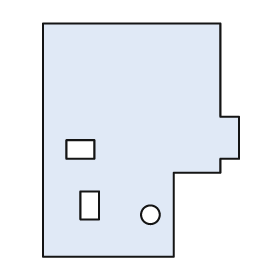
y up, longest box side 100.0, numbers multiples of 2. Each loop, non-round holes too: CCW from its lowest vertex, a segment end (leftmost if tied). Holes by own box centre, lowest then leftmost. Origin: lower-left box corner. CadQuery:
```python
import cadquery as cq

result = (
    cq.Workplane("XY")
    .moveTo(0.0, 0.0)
    .lineTo(56.0, 0.0)
    .lineTo(56.0, 36.0)
    .lineTo(76.0, 36.0)
    .lineTo(76.0, 42.0)
    .lineTo(84.0, 42.0)
    .lineTo(84.0, 60.0)
    .lineTo(76.0, 60.0)
    .lineTo(76.0, 100.0)
    .lineTo(0.0, 100.0)
    .close()
    .moveTo(46.0, 18.0)
    .circle(4.0)
    .moveTo(16.0, 16.0)
    .lineTo(24.0, 16.0)
    .lineTo(24.0, 28.0)
    .lineTo(16.0, 28.0)
    .close()
    .moveTo(10.0, 42.0)
    .lineTo(22.0, 42.0)
    .lineTo(22.0, 50.0)
    .lineTo(10.0, 50.0)
    .close()
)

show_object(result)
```